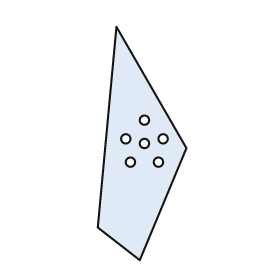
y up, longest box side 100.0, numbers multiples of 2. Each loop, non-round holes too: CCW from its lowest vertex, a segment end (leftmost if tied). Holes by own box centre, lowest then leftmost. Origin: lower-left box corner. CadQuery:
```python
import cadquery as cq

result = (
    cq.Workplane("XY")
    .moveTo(18.0, 0.0)
    .lineTo(38.0, 48.0)
    .lineTo(8.0, 100.0)
    .lineTo(0.0, 14.0)
    .close()
    .moveTo(14.0, 42.0)
    .circle(2.0)
    .moveTo(26.0, 42.0)
    .circle(2.0)
    .moveTo(20.0, 50.0)
    .circle(2.0)
    .moveTo(12.0, 52.0)
    .circle(2.0)
    .moveTo(28.0, 52.0)
    .circle(2.0)
    .moveTo(20.0, 60.0)
    .circle(2.0)
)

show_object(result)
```